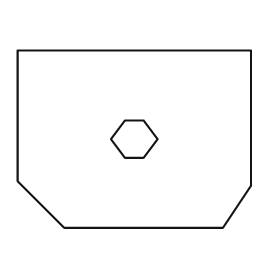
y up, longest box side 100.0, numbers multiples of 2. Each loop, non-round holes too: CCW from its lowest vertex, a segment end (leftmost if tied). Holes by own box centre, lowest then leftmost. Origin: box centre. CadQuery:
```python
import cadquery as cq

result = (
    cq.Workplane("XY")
    .moveTo(-30.0, -38.0)
    .lineTo(38.0, -38.0)
    .lineTo(50.0, -20.0)
    .lineTo(50.0, 38.0)
    .lineTo(-50.0, 38.0)
    .lineTo(-50.0, -18.0)
    .close()
    .moveTo(-4.0, -8.0)
    .lineTo(4.0, -8.0)
    .lineTo(10.0, 0.0)
    .lineTo(4.0, 8.0)
    .lineTo(-4.0, 8.0)
    .lineTo(-10.0, 0.0)
    .close()
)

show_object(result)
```